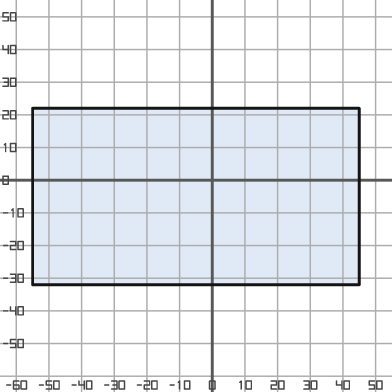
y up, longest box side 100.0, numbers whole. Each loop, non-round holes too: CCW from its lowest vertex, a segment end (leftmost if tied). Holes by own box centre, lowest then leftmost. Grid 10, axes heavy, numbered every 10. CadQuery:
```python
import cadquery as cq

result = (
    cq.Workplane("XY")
    .moveTo(-55.0, -32.0)
    .lineTo(45.0, -32.0)
    .lineTo(45.0, 22.0)
    .lineTo(-55.0, 22.0)
    .close()
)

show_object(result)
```